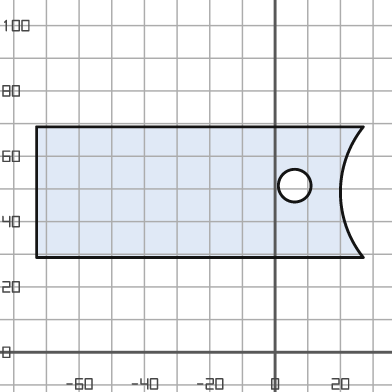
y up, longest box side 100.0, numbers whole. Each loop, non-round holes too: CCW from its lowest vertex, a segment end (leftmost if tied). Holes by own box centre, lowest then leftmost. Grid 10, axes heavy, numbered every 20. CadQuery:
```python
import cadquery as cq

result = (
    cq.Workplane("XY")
    .moveTo(-73.0, 29.0)
    .lineTo(27.0, 29.0)
    .threePointArc((20.0, 49.0), (27.0, 69.0))
    .lineTo(-73.0, 69.0)
    .close()
    .moveTo(6.0, 51.0)
    .circle(5.0)
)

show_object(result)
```